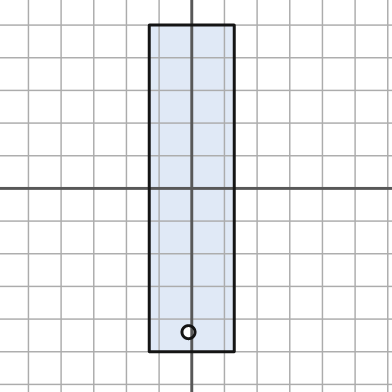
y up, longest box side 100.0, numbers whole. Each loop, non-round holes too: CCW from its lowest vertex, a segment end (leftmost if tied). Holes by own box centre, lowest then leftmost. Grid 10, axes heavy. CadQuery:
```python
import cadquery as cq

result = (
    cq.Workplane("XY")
    .moveTo(-13.0, -50.0)
    .lineTo(13.0, -50.0)
    .lineTo(13.0, 50.0)
    .lineTo(-13.0, 50.0)
    .close()
    .moveTo(-1.0, -44.0)
    .circle(2.0)
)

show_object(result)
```